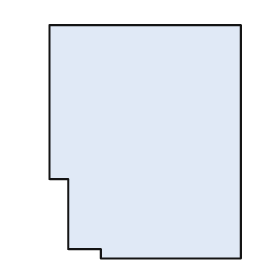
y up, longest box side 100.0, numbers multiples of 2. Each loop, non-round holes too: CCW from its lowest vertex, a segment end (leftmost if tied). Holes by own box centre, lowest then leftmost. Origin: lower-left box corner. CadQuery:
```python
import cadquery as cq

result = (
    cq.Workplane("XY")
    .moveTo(22.0, 0.0)
    .lineTo(82.0, 0.0)
    .lineTo(82.0, 100.0)
    .lineTo(0.0, 100.0)
    .lineTo(0.0, 34.0)
    .lineTo(8.0, 34.0)
    .lineTo(8.0, 4.0)
    .lineTo(22.0, 4.0)
    .close()
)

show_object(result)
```